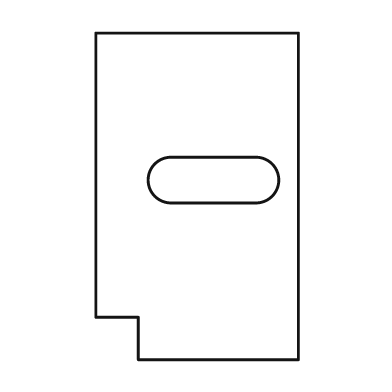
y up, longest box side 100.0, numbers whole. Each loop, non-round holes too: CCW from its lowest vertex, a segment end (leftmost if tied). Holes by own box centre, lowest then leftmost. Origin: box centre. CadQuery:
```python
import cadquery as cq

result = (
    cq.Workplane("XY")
    .moveTo(-18.0, -50.0)
    .lineTo(31.0, -50.0)
    .lineTo(31.0, 50.0)
    .lineTo(-31.0, 50.0)
    .lineTo(-31.0, -37.0)
    .lineTo(-18.0, -37.0)
    .close()
    .moveTo(-8.0, -2.0)
    .lineTo(18.0, -2.0)
    .threePointArc((25.0, 5.0), (18.0, 12.0))
    .lineTo(-8.0, 12.0)
    .threePointArc((-15.0, 5.0), (-8.0, -2.0))
    .close()
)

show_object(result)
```